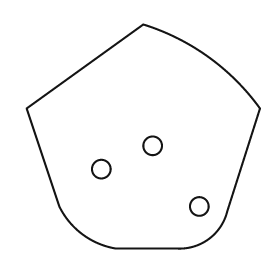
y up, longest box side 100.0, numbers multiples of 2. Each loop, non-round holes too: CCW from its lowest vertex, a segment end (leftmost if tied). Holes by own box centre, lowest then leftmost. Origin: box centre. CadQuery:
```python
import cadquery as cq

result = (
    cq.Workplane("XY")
    .moveTo(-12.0, -48.0)
    .lineTo(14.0, -48.0)
    .threePointArc((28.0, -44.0), (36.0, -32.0))
    .lineTo(50.0, 12.0)
    .threePointArc((28.0, 34.0), (0.0, 48.0))
    .lineTo(-50.0, 12.0)
    .lineTo(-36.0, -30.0)
    .threePointArc((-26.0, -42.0), (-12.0, -48.0))
    .close()
    .moveTo(24.0, -30.0)
    .circle(4.0)
    .moveTo(-18.0, -14.0)
    .circle(4.0)
    .moveTo(4.0, -4.0)
    .circle(4.0)
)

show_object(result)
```